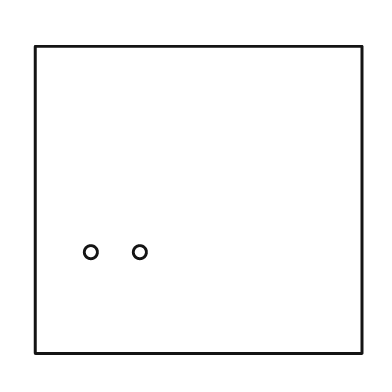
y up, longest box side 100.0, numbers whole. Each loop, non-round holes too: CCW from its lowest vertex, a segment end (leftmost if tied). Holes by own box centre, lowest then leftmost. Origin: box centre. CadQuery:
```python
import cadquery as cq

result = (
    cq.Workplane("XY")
    .moveTo(-50.0, -47.0)
    .lineTo(50.0, -47.0)
    .lineTo(50.0, 47.0)
    .lineTo(-50.0, 47.0)
    .close()
    .moveTo(-33.0, -16.0)
    .circle(2.0)
    .moveTo(-18.0, -16.0)
    .circle(2.0)
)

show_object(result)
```